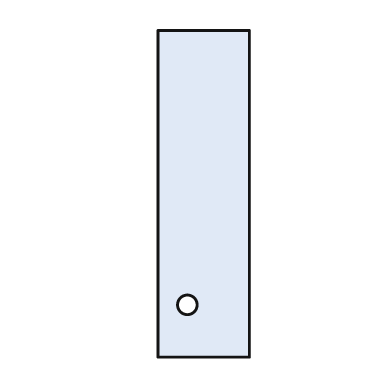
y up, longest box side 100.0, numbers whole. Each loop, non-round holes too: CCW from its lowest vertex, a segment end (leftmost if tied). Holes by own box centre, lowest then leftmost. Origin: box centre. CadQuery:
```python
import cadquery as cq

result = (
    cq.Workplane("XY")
    .moveTo(-14.0, -50.0)
    .lineTo(14.0, -50.0)
    .lineTo(14.0, 50.0)
    .lineTo(-14.0, 50.0)
    .close()
    .moveTo(-5.0, -34.0)
    .circle(3.0)
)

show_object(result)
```